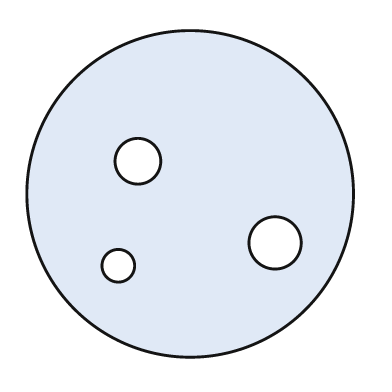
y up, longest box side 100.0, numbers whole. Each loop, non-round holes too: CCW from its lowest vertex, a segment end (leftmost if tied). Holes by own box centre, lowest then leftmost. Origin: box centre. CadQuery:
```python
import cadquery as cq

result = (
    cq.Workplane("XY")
    .moveTo(0.0, 0.0)
    .circle(50.0)
    .moveTo(-22.0, -22.0)
    .circle(5.0)
    .moveTo(26.0, -15.0)
    .circle(8.0)
    .moveTo(-16.0, 10.0)
    .circle(7.0)
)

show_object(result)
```